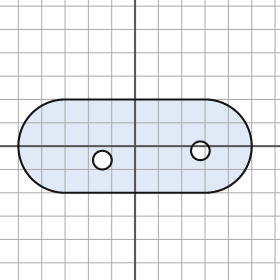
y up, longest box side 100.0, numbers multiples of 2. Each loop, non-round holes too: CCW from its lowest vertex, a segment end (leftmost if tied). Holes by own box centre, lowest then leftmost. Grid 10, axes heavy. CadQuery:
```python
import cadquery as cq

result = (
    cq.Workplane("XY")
    .moveTo(-30.0, -20.0)
    .lineTo(30.0, -20.0)
    .threePointArc((50.0, 0.0), (30.0, 20.0))
    .lineTo(-30.0, 20.0)
    .threePointArc((-50.0, 0.0), (-30.0, -20.0))
    .close()
    .moveTo(-14.0, -6.0)
    .circle(4.0)
    .moveTo(28.0, -2.0)
    .circle(4.0)
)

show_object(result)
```